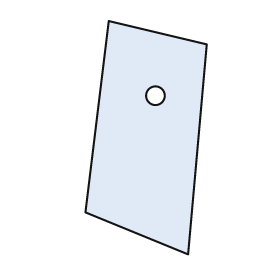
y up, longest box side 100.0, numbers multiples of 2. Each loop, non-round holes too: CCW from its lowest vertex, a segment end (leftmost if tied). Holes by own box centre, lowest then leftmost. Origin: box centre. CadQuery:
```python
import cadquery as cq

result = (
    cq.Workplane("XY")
    .moveTo(18.0, -50.0)
    .lineTo(26.0, 40.0)
    .lineTo(-16.0, 50.0)
    .lineTo(-26.0, -32.0)
    .close()
    .moveTo(4.0, 18.0)
    .circle(4.0)
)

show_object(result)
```